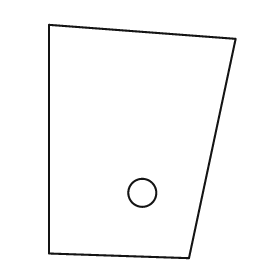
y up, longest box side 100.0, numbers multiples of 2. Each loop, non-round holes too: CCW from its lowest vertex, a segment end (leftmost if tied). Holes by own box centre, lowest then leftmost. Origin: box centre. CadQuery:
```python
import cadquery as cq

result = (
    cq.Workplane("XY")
    .moveTo(20.0, -50.0)
    .lineTo(40.0, 44.0)
    .lineTo(-40.0, 50.0)
    .lineTo(-40.0, -48.0)
    .close()
    .moveTo(0.0, -22.0)
    .circle(6.0)
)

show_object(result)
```